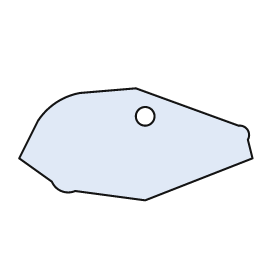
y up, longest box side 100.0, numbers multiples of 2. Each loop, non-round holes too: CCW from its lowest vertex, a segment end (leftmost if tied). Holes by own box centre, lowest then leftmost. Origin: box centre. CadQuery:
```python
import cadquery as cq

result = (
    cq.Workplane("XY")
    .moveTo(4.0, -24.0)
    .lineTo(50.0, -6.0)
    .lineTo(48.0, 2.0)
    .threePointArc((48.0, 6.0), (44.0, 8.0))
    .lineTo(0.0, 24.0)
    .lineTo(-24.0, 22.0)
    .threePointArc((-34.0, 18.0), (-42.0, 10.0))
    .lineTo(-50.0, -6.0)
    .lineTo(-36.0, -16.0)
    .threePointArc((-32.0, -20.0), (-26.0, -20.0))
    .close()
    .moveTo(4.0, 12.0)
    .circle(4.0)
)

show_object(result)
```